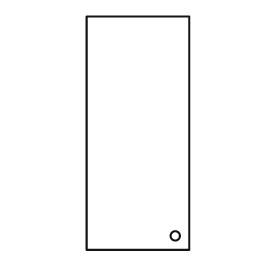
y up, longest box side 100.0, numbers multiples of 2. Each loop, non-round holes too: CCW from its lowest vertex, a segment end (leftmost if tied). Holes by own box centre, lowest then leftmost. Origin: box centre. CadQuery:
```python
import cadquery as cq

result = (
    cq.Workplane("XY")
    .moveTo(-22.0, -50.0)
    .lineTo(22.0, -50.0)
    .lineTo(22.0, 50.0)
    .lineTo(-22.0, 50.0)
    .close()
    .moveTo(16.0, -44.0)
    .circle(2.0)
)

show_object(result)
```